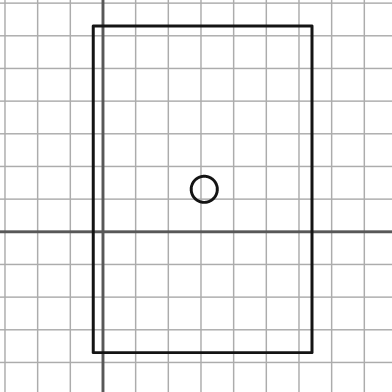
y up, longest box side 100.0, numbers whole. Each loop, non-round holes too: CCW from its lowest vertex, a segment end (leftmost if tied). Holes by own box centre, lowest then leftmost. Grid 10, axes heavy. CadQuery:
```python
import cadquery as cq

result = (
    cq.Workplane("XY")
    .moveTo(-3.0, -37.0)
    .lineTo(64.0, -37.0)
    .lineTo(64.0, 63.0)
    .lineTo(-3.0, 63.0)
    .close()
    .moveTo(31.0, 13.0)
    .circle(4.0)
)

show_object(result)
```